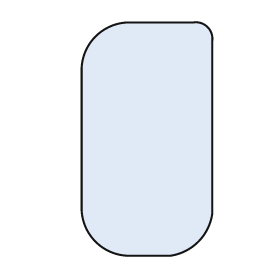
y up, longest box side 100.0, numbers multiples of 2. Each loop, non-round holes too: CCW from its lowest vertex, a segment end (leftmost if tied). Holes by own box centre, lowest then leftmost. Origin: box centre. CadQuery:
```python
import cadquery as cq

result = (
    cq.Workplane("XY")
    .moveTo(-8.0, -50.0)
    .lineTo(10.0, -50.0)
    .threePointArc((22.0, -44.0), (28.0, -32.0))
    .lineTo(28.0, 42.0)
    .threePointArc((26.0, 48.0), (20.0, 50.0))
    .lineTo(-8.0, 50.0)
    .threePointArc((-22.0, 44.0), (-28.0, 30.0))
    .lineTo(-28.0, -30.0)
    .threePointArc((-22.0, -44.0), (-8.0, -50.0))
    .close()
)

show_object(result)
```